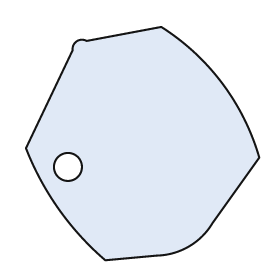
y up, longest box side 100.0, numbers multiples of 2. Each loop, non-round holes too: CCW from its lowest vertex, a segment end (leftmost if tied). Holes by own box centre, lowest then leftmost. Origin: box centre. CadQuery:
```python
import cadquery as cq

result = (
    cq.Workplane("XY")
    .moveTo(-16.0, -50.0)
    .lineTo(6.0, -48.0)
    .threePointArc((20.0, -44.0), (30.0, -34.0))
    .lineTo(50.0, -6.0)
    .threePointArc((34.0, 26.0), (8.0, 50.0))
    .lineTo(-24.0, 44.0)
    .threePointArc((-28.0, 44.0), (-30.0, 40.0))
    .lineTo(-50.0, -2.0)
    .threePointArc((-36.0, -28.0), (-16.0, -50.0))
    .close()
    .moveTo(-32.0, -10.0)
    .circle(6.0)
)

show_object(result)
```